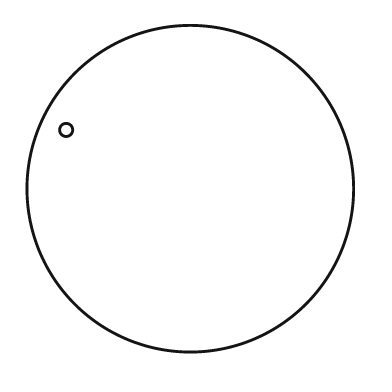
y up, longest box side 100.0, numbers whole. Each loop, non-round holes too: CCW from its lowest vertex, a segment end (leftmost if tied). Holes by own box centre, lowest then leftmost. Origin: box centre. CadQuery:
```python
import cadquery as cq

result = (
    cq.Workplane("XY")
    .moveTo(0.0, 0.0)
    .circle(50.0)
    .moveTo(-38.0, 18.0)
    .circle(2.0)
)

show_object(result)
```